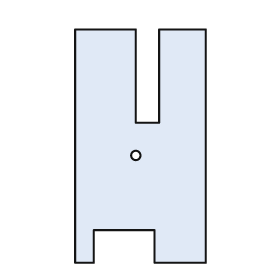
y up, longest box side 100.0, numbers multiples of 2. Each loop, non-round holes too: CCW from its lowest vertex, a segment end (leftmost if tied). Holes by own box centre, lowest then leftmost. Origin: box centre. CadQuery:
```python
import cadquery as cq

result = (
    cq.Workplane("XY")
    .moveTo(-28.0, -50.0)
    .lineTo(-20.0, -50.0)
    .lineTo(-20.0, -36.0)
    .lineTo(6.0, -36.0)
    .lineTo(6.0, -50.0)
    .lineTo(28.0, -50.0)
    .lineTo(28.0, 50.0)
    .lineTo(8.0, 50.0)
    .lineTo(8.0, 10.0)
    .lineTo(-2.0, 10.0)
    .lineTo(-2.0, 50.0)
    .lineTo(-28.0, 50.0)
    .close()
    .moveTo(-2.0, -4.0)
    .circle(2.0)
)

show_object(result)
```